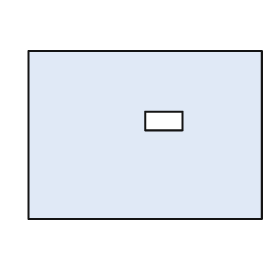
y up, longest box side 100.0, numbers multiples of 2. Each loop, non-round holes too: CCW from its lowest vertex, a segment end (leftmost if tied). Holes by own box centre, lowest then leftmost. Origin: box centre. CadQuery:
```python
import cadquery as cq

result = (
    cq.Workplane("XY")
    .moveTo(-50.0, -36.0)
    .lineTo(50.0, -36.0)
    .lineTo(50.0, 36.0)
    .lineTo(-50.0, 36.0)
    .close()
    .moveTo(0.0, 2.0)
    .lineTo(16.0, 2.0)
    .lineTo(16.0, 10.0)
    .lineTo(0.0, 10.0)
    .close()
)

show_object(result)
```